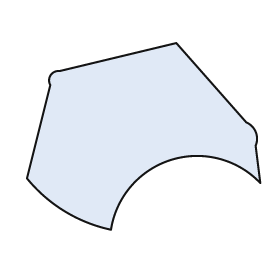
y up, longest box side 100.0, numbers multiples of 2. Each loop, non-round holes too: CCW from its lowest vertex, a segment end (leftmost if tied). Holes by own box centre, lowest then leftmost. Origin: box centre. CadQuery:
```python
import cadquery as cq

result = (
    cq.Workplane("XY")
    .moveTo(-14.0, -40.0)
    .threePointArc((12.0, -10.0), (50.0, -20.0))
    .lineTo(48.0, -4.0)
    .threePointArc((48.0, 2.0), (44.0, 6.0))
    .lineTo(14.0, 40.0)
    .lineTo(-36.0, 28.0)
    .threePointArc((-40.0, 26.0), (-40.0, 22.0))
    .lineTo(-50.0, -18.0)
    .threePointArc((-34.0, -32.0), (-14.0, -40.0))
    .close()
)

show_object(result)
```